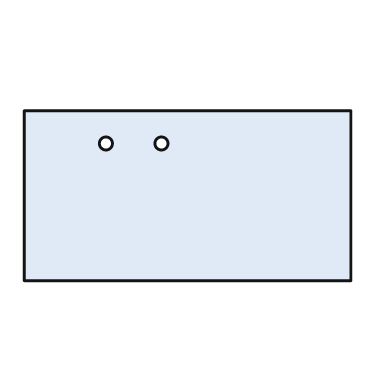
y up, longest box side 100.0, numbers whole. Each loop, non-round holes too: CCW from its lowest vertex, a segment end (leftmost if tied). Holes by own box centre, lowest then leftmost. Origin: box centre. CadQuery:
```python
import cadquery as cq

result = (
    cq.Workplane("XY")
    .moveTo(-50.0, -26.0)
    .lineTo(50.0, -26.0)
    .lineTo(50.0, 26.0)
    .lineTo(-50.0, 26.0)
    .close()
    .moveTo(-25.0, 16.0)
    .circle(2.0)
    .moveTo(-8.0, 16.0)
    .circle(2.0)
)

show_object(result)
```